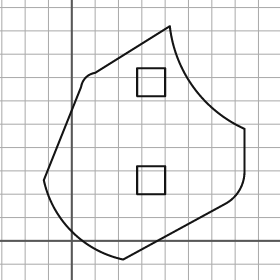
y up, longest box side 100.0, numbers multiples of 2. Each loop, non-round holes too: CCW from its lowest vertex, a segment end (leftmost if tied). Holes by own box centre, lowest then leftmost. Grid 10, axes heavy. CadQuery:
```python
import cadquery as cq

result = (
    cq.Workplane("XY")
    .moveTo(22.0, -8.0)
    .lineTo(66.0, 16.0)
    .threePointArc((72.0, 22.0), (74.0, 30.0))
    .lineTo(74.0, 48.0)
    .threePointArc((52.0, 66.0), (42.0, 92.0))
    .lineTo(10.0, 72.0)
    .threePointArc((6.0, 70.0), (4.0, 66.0))
    .lineTo(-12.0, 26.0)
    .threePointArc((0.0, 4.0), (22.0, -8.0))
    .close()
    .moveTo(28.0, 20.0)
    .lineTo(40.0, 20.0)
    .lineTo(40.0, 32.0)
    .lineTo(28.0, 32.0)
    .close()
    .moveTo(28.0, 62.0)
    .lineTo(40.0, 62.0)
    .lineTo(40.0, 74.0)
    .lineTo(28.0, 74.0)
    .close()
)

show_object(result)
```